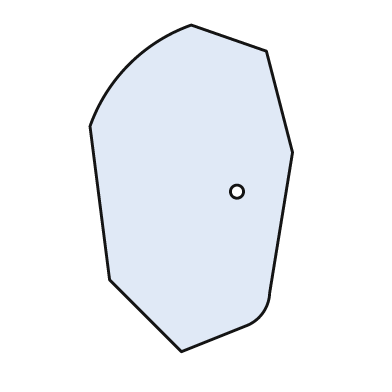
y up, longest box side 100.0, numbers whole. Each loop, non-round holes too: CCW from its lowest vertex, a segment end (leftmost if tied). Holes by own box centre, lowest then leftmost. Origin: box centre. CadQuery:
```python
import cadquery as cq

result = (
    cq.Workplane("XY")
    .moveTo(-3.0, -50.0)
    .lineTo(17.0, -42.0)
    .threePointArc((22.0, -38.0), (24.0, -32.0))
    .lineTo(31.0, 11.0)
    .lineTo(23.0, 42.0)
    .lineTo(0.0, 50.0)
    .threePointArc((-19.0, 38.0), (-31.0, 19.0))
    .lineTo(-25.0, -28.0)
    .close()
    .moveTo(14.0, -1.0)
    .circle(2.0)
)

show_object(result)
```